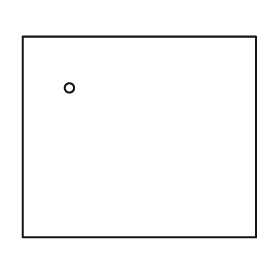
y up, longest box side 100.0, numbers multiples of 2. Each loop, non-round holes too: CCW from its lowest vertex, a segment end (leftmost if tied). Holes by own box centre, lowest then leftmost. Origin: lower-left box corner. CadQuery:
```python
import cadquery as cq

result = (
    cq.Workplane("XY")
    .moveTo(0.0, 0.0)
    .lineTo(100.0, 0.0)
    .lineTo(100.0, 86.0)
    .lineTo(0.0, 86.0)
    .close()
    .moveTo(20.0, 64.0)
    .circle(2.0)
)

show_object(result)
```